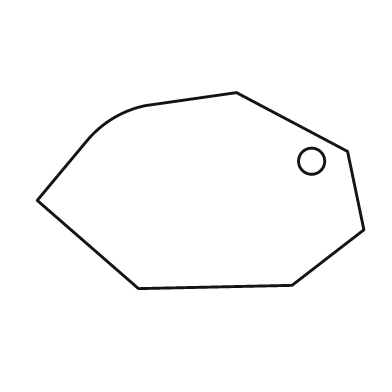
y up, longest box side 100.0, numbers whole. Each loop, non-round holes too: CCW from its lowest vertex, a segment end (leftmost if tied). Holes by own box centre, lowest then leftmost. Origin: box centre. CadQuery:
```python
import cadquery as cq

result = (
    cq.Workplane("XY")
    .moveTo(-19.0, -30.0)
    .lineTo(28.0, -29.0)
    .lineTo(50.0, -12.0)
    .lineTo(45.0, 12.0)
    .lineTo(11.0, 30.0)
    .lineTo(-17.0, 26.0)
    .threePointArc((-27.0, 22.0), (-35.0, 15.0))
    .lineTo(-50.0, -3.0)
    .close()
    .moveTo(34.0, 9.0)
    .circle(4.0)
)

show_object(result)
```